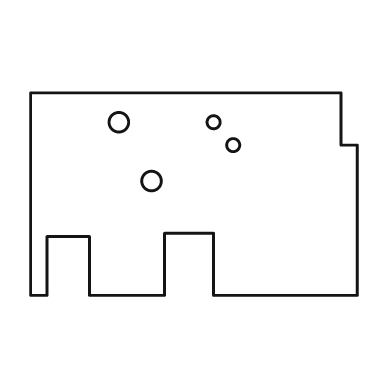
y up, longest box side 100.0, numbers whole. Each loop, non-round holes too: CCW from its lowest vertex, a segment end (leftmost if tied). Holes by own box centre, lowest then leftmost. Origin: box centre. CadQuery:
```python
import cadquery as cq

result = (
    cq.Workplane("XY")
    .moveTo(-50.0, -31.0)
    .lineTo(-45.0, -31.0)
    .lineTo(-45.0, -13.0)
    .lineTo(-32.0, -13.0)
    .lineTo(-32.0, -31.0)
    .lineTo(-9.0, -31.0)
    .lineTo(-9.0, -12.0)
    .lineTo(6.0, -12.0)
    .lineTo(6.0, -31.0)
    .lineTo(50.0, -31.0)
    .lineTo(50.0, 15.0)
    .lineTo(45.0, 15.0)
    .lineTo(45.0, 31.0)
    .lineTo(-50.0, 31.0)
    .close()
    .moveTo(-13.0, 4.0)
    .circle(3.0)
    .moveTo(12.0, 15.0)
    .circle(2.0)
    .moveTo(-23.0, 22.0)
    .circle(3.0)
    .moveTo(6.0, 22.0)
    .circle(2.0)
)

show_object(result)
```